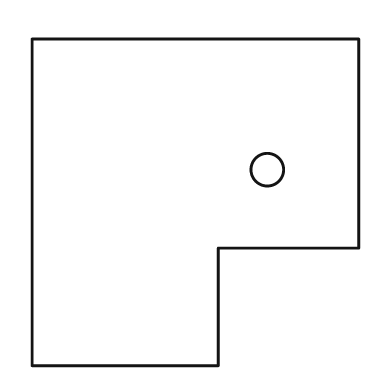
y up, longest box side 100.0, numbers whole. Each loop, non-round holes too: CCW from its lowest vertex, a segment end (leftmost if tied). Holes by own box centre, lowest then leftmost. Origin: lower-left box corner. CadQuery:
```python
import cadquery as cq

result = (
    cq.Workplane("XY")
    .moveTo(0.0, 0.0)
    .lineTo(57.0, 0.0)
    .lineTo(57.0, 36.0)
    .lineTo(100.0, 36.0)
    .lineTo(100.0, 100.0)
    .lineTo(0.0, 100.0)
    .close()
    .moveTo(72.0, 60.0)
    .circle(5.0)
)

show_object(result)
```